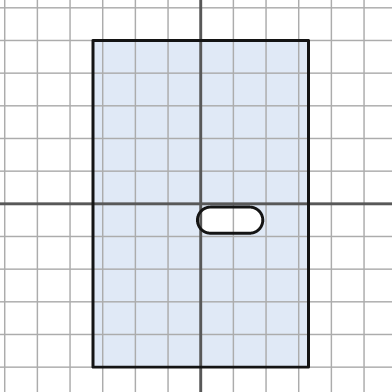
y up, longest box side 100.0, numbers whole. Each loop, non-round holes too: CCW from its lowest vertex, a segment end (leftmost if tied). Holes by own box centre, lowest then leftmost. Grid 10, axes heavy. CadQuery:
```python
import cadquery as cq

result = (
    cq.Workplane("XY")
    .moveTo(-33.0, -50.0)
    .lineTo(33.0, -50.0)
    .lineTo(33.0, 50.0)
    .lineTo(-33.0, 50.0)
    .close()
    .moveTo(3.0, -9.0)
    .lineTo(15.0, -9.0)
    .threePointArc((19.0, -5.0), (15.0, -1.0))
    .lineTo(3.0, -1.0)
    .threePointArc((-1.0, -5.0), (3.0, -9.0))
    .close()
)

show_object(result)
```